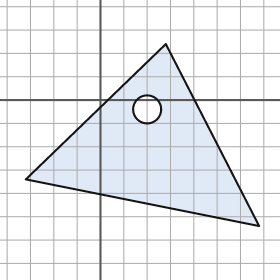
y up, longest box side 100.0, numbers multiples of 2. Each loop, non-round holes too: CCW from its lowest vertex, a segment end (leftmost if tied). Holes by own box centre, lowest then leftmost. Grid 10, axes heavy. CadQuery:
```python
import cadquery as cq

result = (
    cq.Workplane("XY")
    .moveTo(68.0, -54.0)
    .lineTo(28.0, 24.0)
    .lineTo(-32.0, -34.0)
    .close()
    .moveTo(20.0, -4.0)
    .circle(6.0)
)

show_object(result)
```